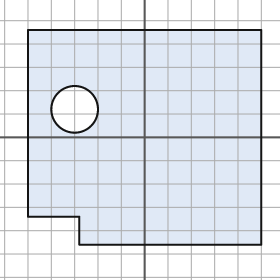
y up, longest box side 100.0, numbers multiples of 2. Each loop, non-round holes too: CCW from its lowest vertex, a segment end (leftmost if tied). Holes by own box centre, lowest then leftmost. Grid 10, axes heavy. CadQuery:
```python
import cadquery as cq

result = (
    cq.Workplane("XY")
    .moveTo(-28.0, -46.0)
    .lineTo(50.0, -46.0)
    .lineTo(50.0, 46.0)
    .lineTo(-50.0, 46.0)
    .lineTo(-50.0, -34.0)
    .lineTo(-28.0, -34.0)
    .close()
    .moveTo(-30.0, 12.0)
    .circle(10.0)
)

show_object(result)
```